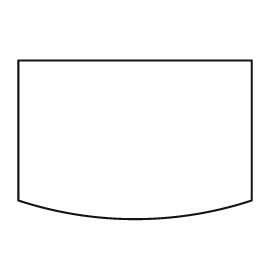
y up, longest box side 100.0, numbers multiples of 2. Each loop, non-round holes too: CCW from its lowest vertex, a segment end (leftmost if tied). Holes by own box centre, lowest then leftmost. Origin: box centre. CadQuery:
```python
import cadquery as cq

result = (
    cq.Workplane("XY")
    .moveTo(-50.0, -26.0)
    .threePointArc((0.0, -34.0), (50.0, -26.0))
    .lineTo(50.0, 34.0)
    .lineTo(-50.0, 34.0)
    .close()
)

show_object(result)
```